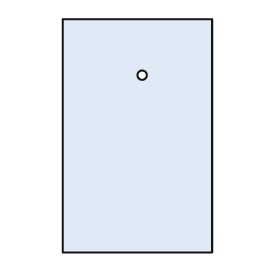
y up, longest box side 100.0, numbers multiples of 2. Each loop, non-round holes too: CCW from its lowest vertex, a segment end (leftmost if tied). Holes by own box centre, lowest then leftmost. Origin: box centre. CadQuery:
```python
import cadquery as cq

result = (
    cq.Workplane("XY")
    .moveTo(-32.0, -50.0)
    .lineTo(32.0, -50.0)
    .lineTo(32.0, 50.0)
    .lineTo(-32.0, 50.0)
    .close()
    .moveTo(2.0, 26.0)
    .circle(2.0)
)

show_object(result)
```